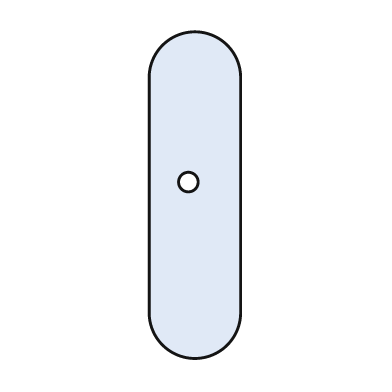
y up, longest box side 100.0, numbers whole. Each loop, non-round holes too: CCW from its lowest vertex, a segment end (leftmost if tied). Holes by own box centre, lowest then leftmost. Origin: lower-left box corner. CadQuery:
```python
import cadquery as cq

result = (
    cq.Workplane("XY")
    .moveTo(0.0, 14.0)
    .threePointArc((14.0, 0.0), (28.0, 14.0))
    .lineTo(28.0, 86.0)
    .threePointArc((14.0, 100.0), (0.0, 86.0))
    .close()
    .moveTo(12.0, 54.0)
    .circle(3.0)
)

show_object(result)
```